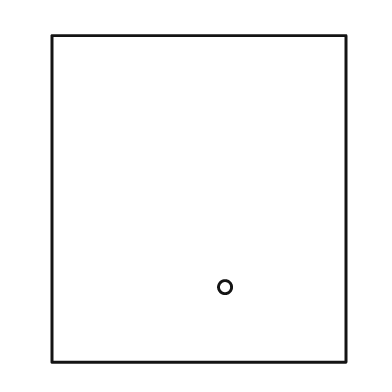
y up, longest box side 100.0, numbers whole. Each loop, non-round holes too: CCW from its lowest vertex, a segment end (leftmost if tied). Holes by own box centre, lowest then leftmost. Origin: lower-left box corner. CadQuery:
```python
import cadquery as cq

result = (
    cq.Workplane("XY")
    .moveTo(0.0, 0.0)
    .lineTo(90.0, 0.0)
    .lineTo(90.0, 100.0)
    .lineTo(0.0, 100.0)
    .close()
    .moveTo(53.0, 23.0)
    .circle(2.0)
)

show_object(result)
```